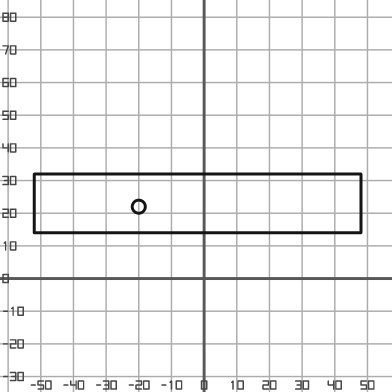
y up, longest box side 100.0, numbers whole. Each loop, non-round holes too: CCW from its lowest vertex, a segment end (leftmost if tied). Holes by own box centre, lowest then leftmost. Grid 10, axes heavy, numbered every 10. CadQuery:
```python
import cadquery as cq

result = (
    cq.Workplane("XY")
    .moveTo(-52.0, 14.0)
    .lineTo(48.0, 14.0)
    .lineTo(48.0, 32.0)
    .lineTo(-52.0, 32.0)
    .close()
    .moveTo(-20.0, 22.0)
    .circle(2.0)
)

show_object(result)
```